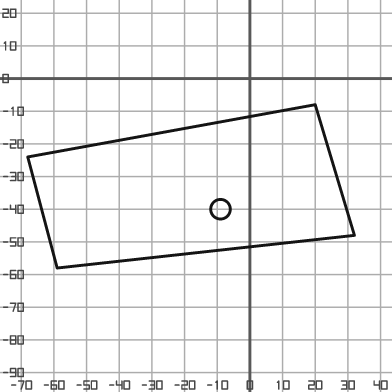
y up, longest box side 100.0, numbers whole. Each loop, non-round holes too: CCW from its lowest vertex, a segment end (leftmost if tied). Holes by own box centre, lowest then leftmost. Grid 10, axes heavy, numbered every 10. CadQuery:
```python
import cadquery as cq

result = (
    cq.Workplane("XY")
    .moveTo(-59.0, -58.0)
    .lineTo(32.0, -48.0)
    .lineTo(20.0, -8.0)
    .lineTo(-68.0, -24.0)
    .close()
    .moveTo(-9.0, -40.0)
    .circle(3.0)
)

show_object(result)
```